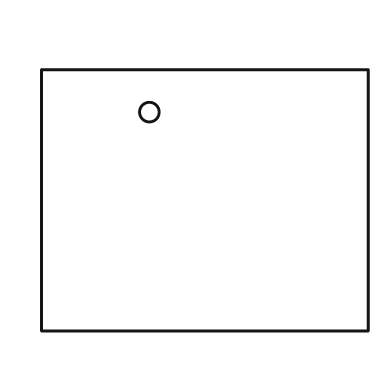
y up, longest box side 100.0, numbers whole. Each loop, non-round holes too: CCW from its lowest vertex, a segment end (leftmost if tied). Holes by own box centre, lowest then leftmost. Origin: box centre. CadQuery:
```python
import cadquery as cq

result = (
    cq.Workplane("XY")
    .moveTo(-50.0, -40.0)
    .lineTo(50.0, -40.0)
    .lineTo(50.0, 40.0)
    .lineTo(-50.0, 40.0)
    .close()
    .moveTo(-17.0, 27.0)
    .circle(3.0)
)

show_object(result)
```